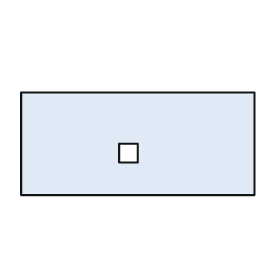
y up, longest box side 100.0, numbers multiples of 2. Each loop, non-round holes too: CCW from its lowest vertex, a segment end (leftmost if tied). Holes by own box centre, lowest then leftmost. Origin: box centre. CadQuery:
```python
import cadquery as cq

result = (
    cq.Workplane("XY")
    .moveTo(-50.0, -22.0)
    .lineTo(50.0, -22.0)
    .lineTo(50.0, 22.0)
    .lineTo(-50.0, 22.0)
    .close()
    .moveTo(-8.0, -8.0)
    .lineTo(0.0, -8.0)
    .lineTo(0.0, 0.0)
    .lineTo(-8.0, 0.0)
    .close()
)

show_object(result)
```